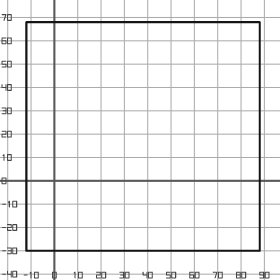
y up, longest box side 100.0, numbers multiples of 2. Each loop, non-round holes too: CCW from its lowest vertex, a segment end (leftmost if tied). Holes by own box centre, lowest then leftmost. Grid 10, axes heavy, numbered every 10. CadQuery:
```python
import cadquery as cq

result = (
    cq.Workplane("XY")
    .moveTo(-12.0, -30.0)
    .lineTo(88.0, -30.0)
    .lineTo(88.0, 68.0)
    .lineTo(-12.0, 68.0)
    .close()
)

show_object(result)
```